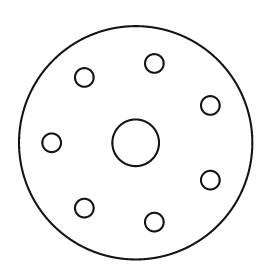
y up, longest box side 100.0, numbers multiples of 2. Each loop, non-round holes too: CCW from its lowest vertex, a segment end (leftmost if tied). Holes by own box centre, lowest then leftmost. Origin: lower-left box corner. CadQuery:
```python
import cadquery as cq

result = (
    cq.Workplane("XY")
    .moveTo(50.0, 50.0)
    .circle(50.0)
    .moveTo(58.0, 16.0)
    .circle(4.0)
    .moveTo(28.0, 22.0)
    .circle(4.0)
    .moveTo(82.0, 34.0)
    .circle(4.0)
    .moveTo(14.0, 50.0)
    .circle(4.0)
    .moveTo(50.0, 50.0)
    .circle(10.0)
    .moveTo(82.0, 66.0)
    .circle(4.0)
    .moveTo(28.0, 78.0)
    .circle(4.0)
    .moveTo(58.0, 84.0)
    .circle(4.0)
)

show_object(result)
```